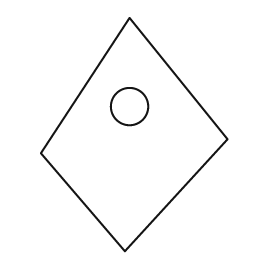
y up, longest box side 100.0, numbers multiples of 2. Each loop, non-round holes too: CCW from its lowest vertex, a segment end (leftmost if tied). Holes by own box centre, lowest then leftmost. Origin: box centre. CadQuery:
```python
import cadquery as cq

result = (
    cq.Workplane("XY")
    .moveTo(-4.0, -50.0)
    .lineTo(40.0, -2.0)
    .lineTo(-2.0, 50.0)
    .lineTo(-40.0, -8.0)
    .close()
    .moveTo(-2.0, 12.0)
    .circle(8.0)
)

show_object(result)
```